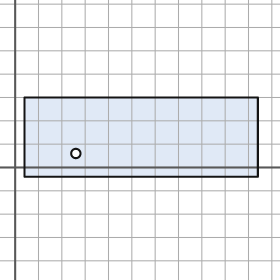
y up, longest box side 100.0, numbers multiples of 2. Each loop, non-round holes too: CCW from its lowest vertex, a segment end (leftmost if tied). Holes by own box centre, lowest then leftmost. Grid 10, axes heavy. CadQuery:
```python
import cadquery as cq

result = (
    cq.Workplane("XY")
    .moveTo(4.0, -4.0)
    .lineTo(104.0, -4.0)
    .lineTo(104.0, 30.0)
    .lineTo(4.0, 30.0)
    .close()
    .moveTo(26.0, 6.0)
    .circle(2.0)
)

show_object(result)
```